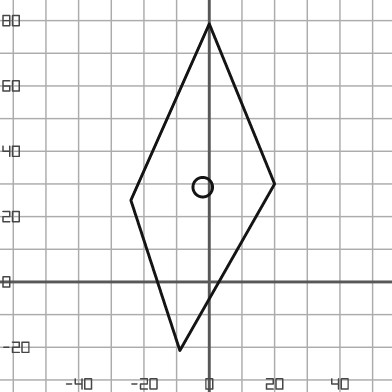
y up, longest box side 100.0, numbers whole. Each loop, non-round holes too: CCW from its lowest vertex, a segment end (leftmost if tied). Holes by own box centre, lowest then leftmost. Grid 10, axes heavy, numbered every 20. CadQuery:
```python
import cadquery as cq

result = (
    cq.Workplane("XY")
    .moveTo(-9.0, -21.0)
    .lineTo(20.0, 30.0)
    .lineTo(0.0, 79.0)
    .lineTo(-24.0, 25.0)
    .close()
    .moveTo(-2.0, 29.0)
    .circle(3.0)
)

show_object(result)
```